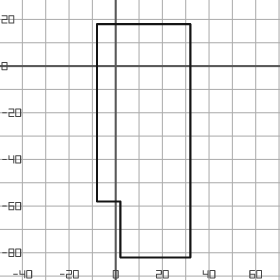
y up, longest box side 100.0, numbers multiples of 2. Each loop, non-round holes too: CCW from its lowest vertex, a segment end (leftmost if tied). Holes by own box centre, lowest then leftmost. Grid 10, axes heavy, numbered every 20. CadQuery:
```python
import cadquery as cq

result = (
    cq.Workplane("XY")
    .moveTo(2.0, -82.0)
    .lineTo(32.0, -82.0)
    .lineTo(32.0, 18.0)
    .lineTo(-8.0, 18.0)
    .lineTo(-8.0, -58.0)
    .lineTo(2.0, -58.0)
    .close()
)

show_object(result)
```